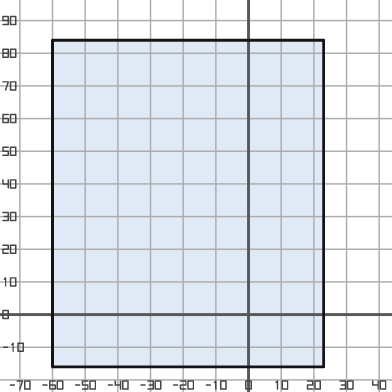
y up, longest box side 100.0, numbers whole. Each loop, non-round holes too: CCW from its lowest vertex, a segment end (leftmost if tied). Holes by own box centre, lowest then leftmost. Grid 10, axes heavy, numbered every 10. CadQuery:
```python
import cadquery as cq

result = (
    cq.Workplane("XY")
    .moveTo(-60.0, -16.0)
    .lineTo(23.0, -16.0)
    .lineTo(23.0, 84.0)
    .lineTo(-60.0, 84.0)
    .close()
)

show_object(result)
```